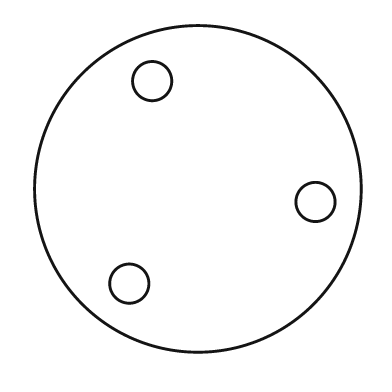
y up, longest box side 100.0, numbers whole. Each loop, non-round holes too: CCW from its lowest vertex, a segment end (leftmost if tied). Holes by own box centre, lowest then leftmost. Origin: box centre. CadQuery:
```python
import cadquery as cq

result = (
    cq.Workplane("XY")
    .moveTo(0.0, 0.0)
    .circle(50.0)
    .moveTo(-21.0, -29.0)
    .circle(6.0)
    .moveTo(36.0, -4.0)
    .circle(6.0)
    .moveTo(-14.0, 33.0)
    .circle(6.0)
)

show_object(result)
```